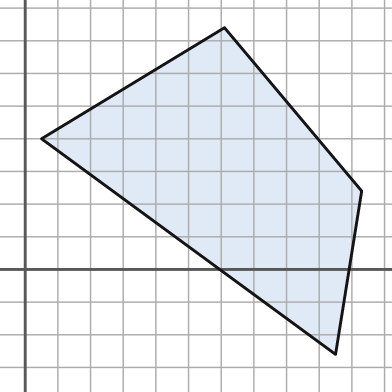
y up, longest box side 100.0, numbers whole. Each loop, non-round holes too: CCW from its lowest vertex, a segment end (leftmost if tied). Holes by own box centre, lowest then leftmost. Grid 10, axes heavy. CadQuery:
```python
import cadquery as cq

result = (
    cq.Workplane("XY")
    .moveTo(95.0, -26.0)
    .lineTo(103.0, 24.0)
    .lineTo(61.0, 74.0)
    .lineTo(5.0, 40.0)
    .close()
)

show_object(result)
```